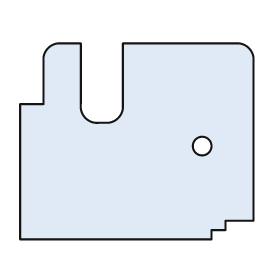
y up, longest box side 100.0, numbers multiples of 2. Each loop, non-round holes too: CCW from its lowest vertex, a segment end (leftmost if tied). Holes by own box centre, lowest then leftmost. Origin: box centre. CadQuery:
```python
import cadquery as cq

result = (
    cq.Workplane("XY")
    .moveTo(-50.0, -42.0)
    .lineTo(32.0, -42.0)
    .lineTo(32.0, -38.0)
    .lineTo(38.0, -38.0)
    .lineTo(38.0, -34.0)
    .lineTo(50.0, -34.0)
    .lineTo(50.0, 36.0)
    .threePointArc((48.0, 40.0), (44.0, 42.0))
    .lineTo(-6.0, 42.0)
    .lineTo(-6.0, 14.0)
    .threePointArc((-8.0, 10.0), (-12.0, 8.0))
    .lineTo(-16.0, 8.0)
    .threePointArc((-22.0, 10.0), (-24.0, 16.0))
    .lineTo(-24.0, 42.0)
    .lineTo(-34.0, 42.0)
    .threePointArc((-38.0, 40.0), (-40.0, 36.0))
    .lineTo(-40.0, 16.0)
    .lineTo(-50.0, 16.0)
    .close()
    .moveTo(28.0, -2.0)
    .circle(4.0)
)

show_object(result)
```